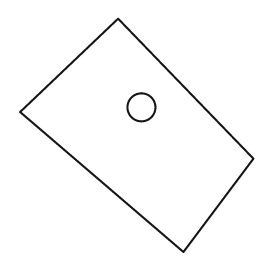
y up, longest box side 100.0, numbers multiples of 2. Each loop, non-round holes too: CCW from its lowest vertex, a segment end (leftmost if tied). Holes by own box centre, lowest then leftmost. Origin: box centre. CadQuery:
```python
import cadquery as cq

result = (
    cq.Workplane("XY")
    .moveTo(20.0, -50.0)
    .lineTo(50.0, -10.0)
    .lineTo(-8.0, 50.0)
    .lineTo(-50.0, 10.0)
    .close()
    .moveTo(2.0, 12.0)
    .circle(6.0)
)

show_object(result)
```